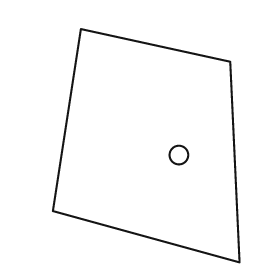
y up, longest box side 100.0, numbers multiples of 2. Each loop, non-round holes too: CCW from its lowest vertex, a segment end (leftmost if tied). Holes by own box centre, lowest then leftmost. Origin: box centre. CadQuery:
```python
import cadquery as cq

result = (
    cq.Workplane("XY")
    .moveTo(40.0, -50.0)
    .lineTo(36.0, 36.0)
    .lineTo(-28.0, 50.0)
    .lineTo(-40.0, -28.0)
    .close()
    .moveTo(14.0, -4.0)
    .circle(4.0)
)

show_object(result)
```